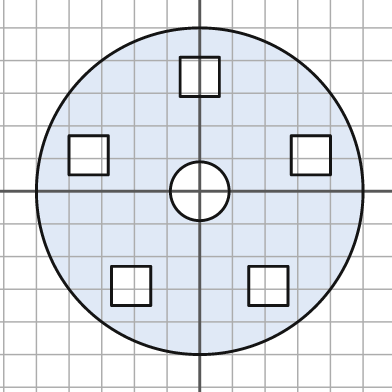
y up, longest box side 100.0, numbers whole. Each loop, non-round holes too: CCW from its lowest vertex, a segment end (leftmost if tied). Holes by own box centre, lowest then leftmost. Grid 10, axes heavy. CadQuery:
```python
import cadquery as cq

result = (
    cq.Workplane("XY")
    .moveTo(0.0, 0.0)
    .circle(50.0)
    .moveTo(-27.0, -35.0)
    .lineTo(-15.0, -35.0)
    .lineTo(-15.0, -23.0)
    .lineTo(-27.0, -23.0)
    .close()
    .moveTo(15.0, -35.0)
    .lineTo(27.0, -35.0)
    .lineTo(27.0, -23.0)
    .lineTo(15.0, -23.0)
    .close()
    .moveTo(0.0, 0.0)
    .circle(9.0)
    .moveTo(-40.0, 5.0)
    .lineTo(-28.0, 5.0)
    .lineTo(-28.0, 17.0)
    .lineTo(-40.0, 17.0)
    .close()
    .moveTo(28.0, 5.0)
    .lineTo(40.0, 5.0)
    .lineTo(40.0, 17.0)
    .lineTo(28.0, 17.0)
    .close()
    .moveTo(-6.0, 29.0)
    .lineTo(6.0, 29.0)
    .lineTo(6.0, 41.0)
    .lineTo(-6.0, 41.0)
    .close()
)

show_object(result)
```